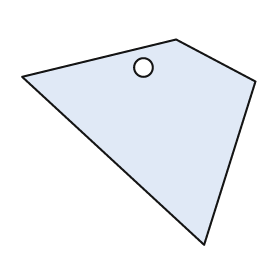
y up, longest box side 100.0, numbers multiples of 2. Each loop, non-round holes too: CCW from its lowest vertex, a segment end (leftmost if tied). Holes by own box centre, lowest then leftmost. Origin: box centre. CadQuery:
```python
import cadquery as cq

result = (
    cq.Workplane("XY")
    .moveTo(28.0, -44.0)
    .lineTo(50.0, 26.0)
    .lineTo(16.0, 44.0)
    .lineTo(-50.0, 28.0)
    .close()
    .moveTo(2.0, 32.0)
    .circle(4.0)
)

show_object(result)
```